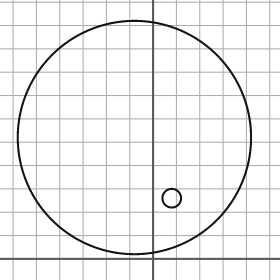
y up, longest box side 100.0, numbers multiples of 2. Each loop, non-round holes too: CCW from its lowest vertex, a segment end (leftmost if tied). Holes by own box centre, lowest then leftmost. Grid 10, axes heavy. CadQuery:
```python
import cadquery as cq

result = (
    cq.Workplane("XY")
    .moveTo(-8.0, 52.0)
    .circle(50.0)
    .moveTo(8.0, 26.0)
    .circle(4.0)
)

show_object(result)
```